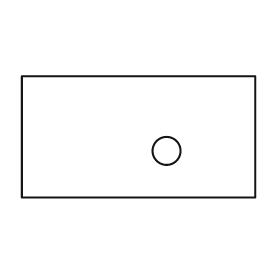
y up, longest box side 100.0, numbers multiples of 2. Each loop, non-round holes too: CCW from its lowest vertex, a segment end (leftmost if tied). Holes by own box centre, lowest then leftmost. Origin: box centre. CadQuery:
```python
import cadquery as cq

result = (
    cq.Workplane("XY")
    .moveTo(-50.0, -26.0)
    .lineTo(50.0, -26.0)
    .lineTo(50.0, 26.0)
    .lineTo(-50.0, 26.0)
    .close()
    .moveTo(12.0, -6.0)
    .circle(6.0)
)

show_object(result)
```